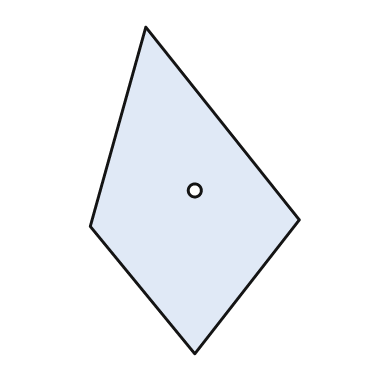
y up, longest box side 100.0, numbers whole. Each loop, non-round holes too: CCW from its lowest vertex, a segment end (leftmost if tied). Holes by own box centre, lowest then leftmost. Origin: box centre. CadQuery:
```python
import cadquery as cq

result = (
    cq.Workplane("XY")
    .moveTo(0.0, -50.0)
    .lineTo(32.0, -9.0)
    .lineTo(-15.0, 50.0)
    .lineTo(-32.0, -11.0)
    .close()
    .moveTo(0.0, 0.0)
    .circle(2.0)
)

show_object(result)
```